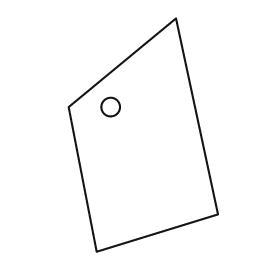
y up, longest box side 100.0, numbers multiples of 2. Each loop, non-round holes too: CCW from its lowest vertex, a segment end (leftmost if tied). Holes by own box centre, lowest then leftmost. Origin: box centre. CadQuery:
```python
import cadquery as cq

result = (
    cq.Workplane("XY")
    .moveTo(-20.0, -50.0)
    .lineTo(32.0, -34.0)
    .lineTo(14.0, 50.0)
    .lineTo(-32.0, 12.0)
    .close()
    .moveTo(-14.0, 12.0)
    .circle(4.0)
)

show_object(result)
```